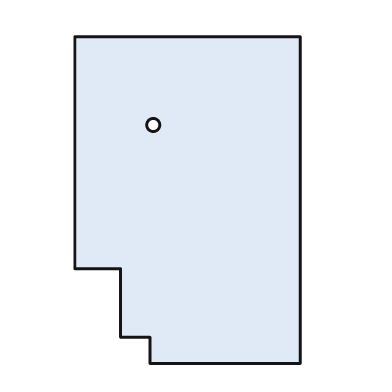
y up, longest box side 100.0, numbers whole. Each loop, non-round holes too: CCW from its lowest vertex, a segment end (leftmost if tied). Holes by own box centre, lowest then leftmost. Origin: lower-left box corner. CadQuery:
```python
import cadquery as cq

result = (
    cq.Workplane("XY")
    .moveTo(23.0, 0.0)
    .lineTo(69.0, 0.0)
    .lineTo(69.0, 100.0)
    .lineTo(0.0, 100.0)
    .lineTo(0.0, 29.0)
    .lineTo(14.0, 29.0)
    .lineTo(14.0, 8.0)
    .lineTo(23.0, 8.0)
    .close()
    .moveTo(24.0, 73.0)
    .circle(2.0)
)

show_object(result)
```